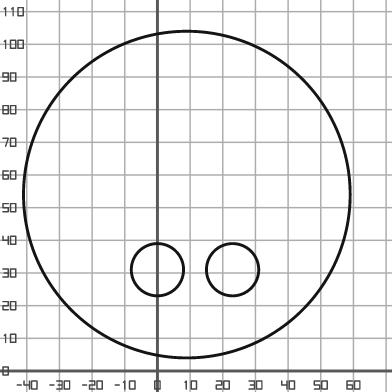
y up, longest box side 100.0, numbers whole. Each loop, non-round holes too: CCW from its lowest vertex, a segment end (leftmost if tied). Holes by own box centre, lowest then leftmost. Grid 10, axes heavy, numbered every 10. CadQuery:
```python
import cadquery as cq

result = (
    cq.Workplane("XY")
    .moveTo(9.0, 54.0)
    .circle(50.0)
    .moveTo(0.0, 31.0)
    .circle(8.0)
    .moveTo(23.0, 31.0)
    .circle(8.0)
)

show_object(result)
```